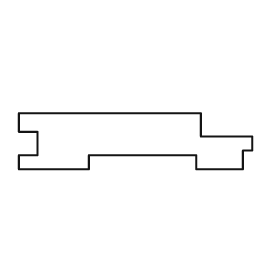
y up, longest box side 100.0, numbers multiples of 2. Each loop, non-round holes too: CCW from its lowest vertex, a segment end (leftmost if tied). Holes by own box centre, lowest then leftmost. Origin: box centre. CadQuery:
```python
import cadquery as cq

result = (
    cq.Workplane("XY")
    .moveTo(-50.0, -12.0)
    .lineTo(-20.0, -12.0)
    .lineTo(-20.0, -6.0)
    .lineTo(26.0, -6.0)
    .lineTo(26.0, -12.0)
    .lineTo(46.0, -12.0)
    .lineTo(46.0, -4.0)
    .lineTo(50.0, -4.0)
    .lineTo(50.0, 2.0)
    .lineTo(28.0, 2.0)
    .lineTo(28.0, 12.0)
    .lineTo(-50.0, 12.0)
    .lineTo(-50.0, 4.0)
    .lineTo(-42.0, 4.0)
    .lineTo(-42.0, -6.0)
    .lineTo(-50.0, -6.0)
    .close()
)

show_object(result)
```